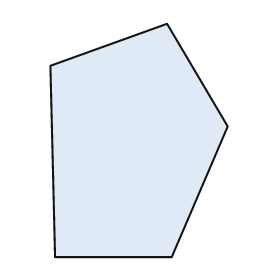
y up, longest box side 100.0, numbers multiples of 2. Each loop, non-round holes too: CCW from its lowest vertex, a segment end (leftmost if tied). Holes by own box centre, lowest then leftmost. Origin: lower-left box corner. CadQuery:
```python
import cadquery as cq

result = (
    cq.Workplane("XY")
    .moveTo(2.0, 0.0)
    .lineTo(52.0, 0.0)
    .lineTo(76.0, 56.0)
    .lineTo(50.0, 100.0)
    .lineTo(0.0, 82.0)
    .close()
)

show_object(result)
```